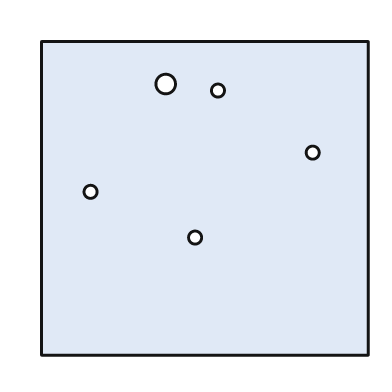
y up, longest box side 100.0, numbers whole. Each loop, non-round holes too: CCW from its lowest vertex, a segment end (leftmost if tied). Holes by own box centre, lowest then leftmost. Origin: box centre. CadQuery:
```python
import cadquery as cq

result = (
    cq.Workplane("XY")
    .moveTo(-50.0, -48.0)
    .lineTo(50.0, -48.0)
    .lineTo(50.0, 48.0)
    .lineTo(-50.0, 48.0)
    .close()
    .moveTo(-3.0, -12.0)
    .circle(2.0)
    .moveTo(-35.0, 2.0)
    .circle(2.0)
    .moveTo(33.0, 14.0)
    .circle(2.0)
    .moveTo(4.0, 33.0)
    .circle(2.0)
    .moveTo(-12.0, 35.0)
    .circle(3.0)
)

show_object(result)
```